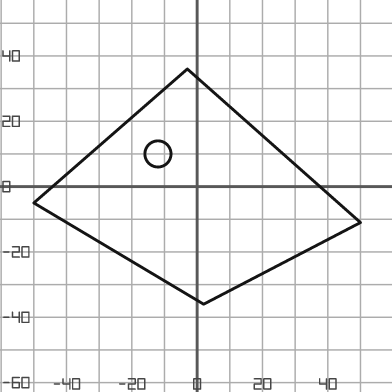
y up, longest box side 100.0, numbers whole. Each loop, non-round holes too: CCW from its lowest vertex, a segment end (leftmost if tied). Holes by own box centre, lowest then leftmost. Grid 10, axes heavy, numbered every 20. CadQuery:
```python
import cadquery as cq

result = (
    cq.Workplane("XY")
    .moveTo(2.0, -36.0)
    .lineTo(50.0, -11.0)
    .lineTo(-3.0, 36.0)
    .lineTo(-50.0, -5.0)
    .close()
    .moveTo(-12.0, 10.0)
    .circle(4.0)
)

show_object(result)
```